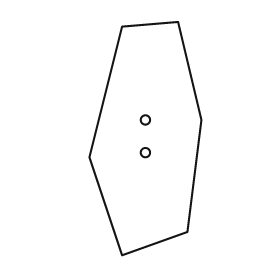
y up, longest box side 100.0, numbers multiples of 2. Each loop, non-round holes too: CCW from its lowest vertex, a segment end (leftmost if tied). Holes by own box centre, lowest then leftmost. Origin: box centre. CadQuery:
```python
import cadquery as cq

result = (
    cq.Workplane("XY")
    .moveTo(-10.0, -50.0)
    .lineTo(18.0, -40.0)
    .lineTo(24.0, 8.0)
    .lineTo(14.0, 50.0)
    .lineTo(-10.0, 48.0)
    .lineTo(-24.0, -8.0)
    .close()
    .moveTo(0.0, -6.0)
    .circle(2.0)
    .moveTo(0.0, 8.0)
    .circle(2.0)
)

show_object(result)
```